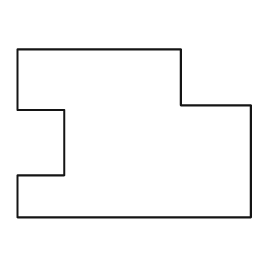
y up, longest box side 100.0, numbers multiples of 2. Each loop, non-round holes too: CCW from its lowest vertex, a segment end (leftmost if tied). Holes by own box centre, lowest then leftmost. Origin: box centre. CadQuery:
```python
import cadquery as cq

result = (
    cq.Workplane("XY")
    .moveTo(-50.0, -36.0)
    .lineTo(50.0, -36.0)
    .lineTo(50.0, 12.0)
    .lineTo(20.0, 12.0)
    .lineTo(20.0, 36.0)
    .lineTo(-50.0, 36.0)
    .lineTo(-50.0, 10.0)
    .lineTo(-30.0, 10.0)
    .lineTo(-30.0, -18.0)
    .lineTo(-50.0, -18.0)
    .close()
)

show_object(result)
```